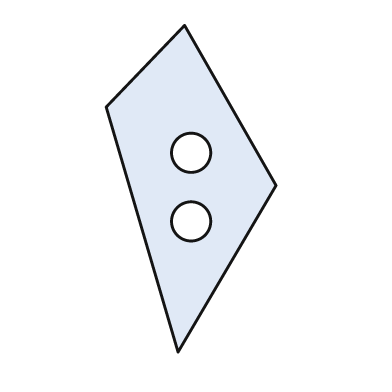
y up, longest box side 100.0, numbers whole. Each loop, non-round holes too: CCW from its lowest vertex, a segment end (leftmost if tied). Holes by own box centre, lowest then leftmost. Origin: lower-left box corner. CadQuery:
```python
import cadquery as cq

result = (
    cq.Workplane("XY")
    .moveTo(22.0, 0.0)
    .lineTo(52.0, 51.0)
    .lineTo(24.0, 100.0)
    .lineTo(0.0, 75.0)
    .close()
    .moveTo(26.0, 40.0)
    .circle(6.0)
    .moveTo(26.0, 61.0)
    .circle(6.0)
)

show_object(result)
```